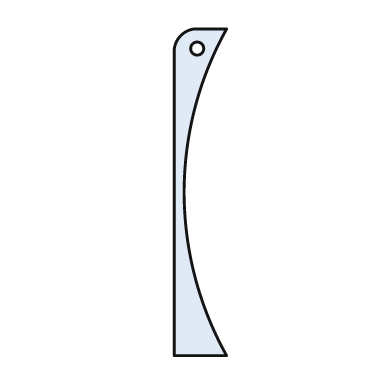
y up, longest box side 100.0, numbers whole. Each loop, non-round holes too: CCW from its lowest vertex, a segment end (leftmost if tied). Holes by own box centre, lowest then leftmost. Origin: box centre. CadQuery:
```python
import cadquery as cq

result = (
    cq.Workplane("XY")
    .moveTo(-8.0, -50.0)
    .lineTo(8.0, -50.0)
    .threePointArc((-5.0, 0.0), (8.0, 50.0))
    .lineTo(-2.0, 50.0)
    .threePointArc((-6.0, 48.0), (-8.0, 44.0))
    .close()
    .moveTo(-1.0, 44.0)
    .circle(2.0)
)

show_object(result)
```